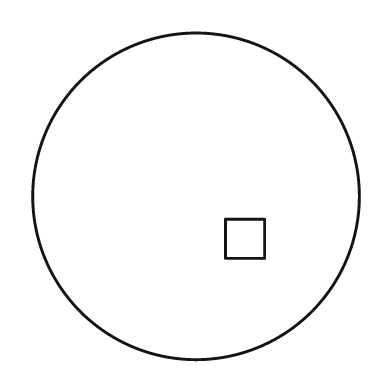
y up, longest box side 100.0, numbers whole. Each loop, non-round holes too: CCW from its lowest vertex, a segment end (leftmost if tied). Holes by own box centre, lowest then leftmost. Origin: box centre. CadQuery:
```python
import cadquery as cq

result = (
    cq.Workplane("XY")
    .moveTo(0.0, 0.0)
    .circle(50.0)
    .moveTo(9.0, -19.0)
    .lineTo(21.0, -19.0)
    .lineTo(21.0, -7.0)
    .lineTo(9.0, -7.0)
    .close()
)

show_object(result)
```